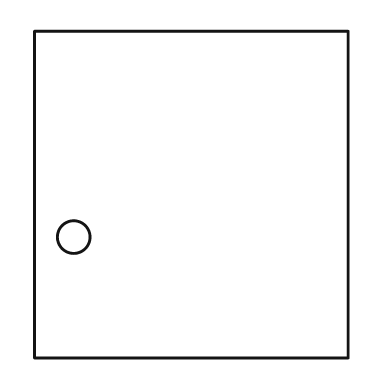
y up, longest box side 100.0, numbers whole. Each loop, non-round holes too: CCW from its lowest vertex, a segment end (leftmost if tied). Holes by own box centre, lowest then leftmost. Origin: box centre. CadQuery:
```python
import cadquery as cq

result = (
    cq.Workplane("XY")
    .moveTo(-48.0, -50.0)
    .lineTo(48.0, -50.0)
    .lineTo(48.0, 50.0)
    .lineTo(-48.0, 50.0)
    .close()
    .moveTo(-36.0, -13.0)
    .circle(5.0)
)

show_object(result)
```